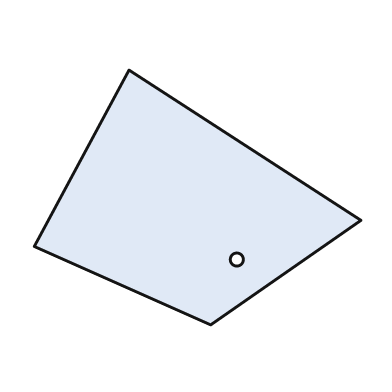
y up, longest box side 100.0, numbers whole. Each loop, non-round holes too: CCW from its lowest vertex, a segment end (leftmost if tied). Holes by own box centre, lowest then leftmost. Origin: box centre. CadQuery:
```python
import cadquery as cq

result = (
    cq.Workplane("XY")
    .moveTo(4.0, -39.0)
    .lineTo(50.0, -7.0)
    .lineTo(-21.0, 39.0)
    .lineTo(-50.0, -15.0)
    .close()
    .moveTo(12.0, -19.0)
    .circle(2.0)
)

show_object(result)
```